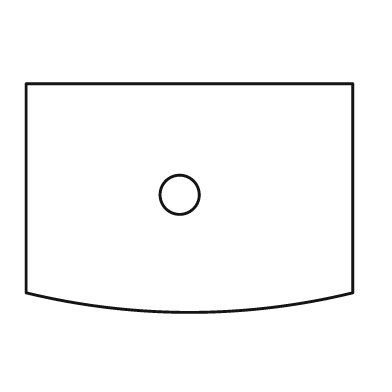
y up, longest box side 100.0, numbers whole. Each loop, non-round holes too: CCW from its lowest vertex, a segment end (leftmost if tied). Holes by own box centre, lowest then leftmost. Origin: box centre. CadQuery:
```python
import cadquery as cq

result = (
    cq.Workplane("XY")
    .moveTo(-50.0, -29.0)
    .threePointArc((0.0, -35.0), (50.0, -29.0))
    .lineTo(50.0, 35.0)
    .lineTo(-50.0, 35.0)
    .close()
    .moveTo(-3.0, 1.0)
    .circle(6.0)
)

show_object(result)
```